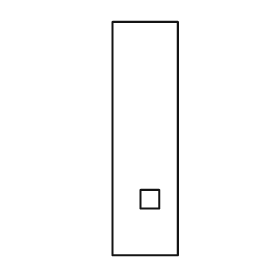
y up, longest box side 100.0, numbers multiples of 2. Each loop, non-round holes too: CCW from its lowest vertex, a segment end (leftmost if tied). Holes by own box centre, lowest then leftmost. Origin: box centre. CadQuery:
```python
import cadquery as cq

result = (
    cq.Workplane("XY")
    .moveTo(-14.0, -50.0)
    .lineTo(14.0, -50.0)
    .lineTo(14.0, 50.0)
    .lineTo(-14.0, 50.0)
    .close()
    .moveTo(-2.0, -30.0)
    .lineTo(6.0, -30.0)
    .lineTo(6.0, -22.0)
    .lineTo(-2.0, -22.0)
    .close()
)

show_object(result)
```